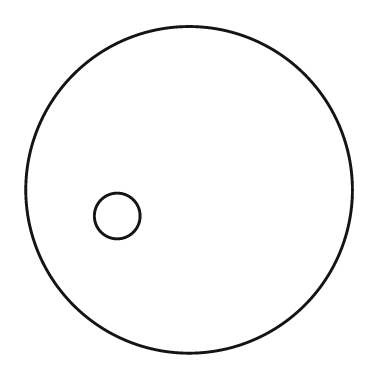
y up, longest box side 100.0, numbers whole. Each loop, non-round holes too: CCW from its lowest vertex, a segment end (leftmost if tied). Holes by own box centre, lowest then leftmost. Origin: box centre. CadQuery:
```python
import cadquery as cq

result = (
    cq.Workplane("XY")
    .moveTo(0.0, 0.0)
    .circle(50.0)
    .moveTo(-22.0, -8.0)
    .circle(7.0)
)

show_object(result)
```